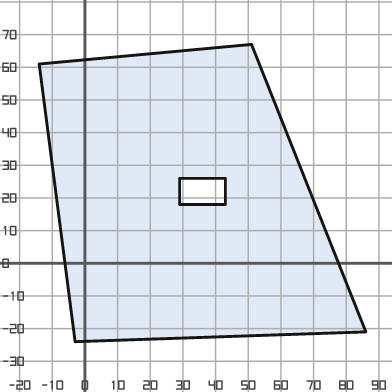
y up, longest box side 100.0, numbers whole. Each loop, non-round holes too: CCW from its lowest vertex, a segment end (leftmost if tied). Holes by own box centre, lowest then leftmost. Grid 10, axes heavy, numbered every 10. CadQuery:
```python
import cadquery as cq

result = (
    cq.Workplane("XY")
    .moveTo(-3.0, -24.0)
    .lineTo(86.0, -21.0)
    .lineTo(51.0, 67.0)
    .lineTo(-14.0, 61.0)
    .close()
    .moveTo(29.0, 18.0)
    .lineTo(43.0, 18.0)
    .lineTo(43.0, 26.0)
    .lineTo(29.0, 26.0)
    .close()
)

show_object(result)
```